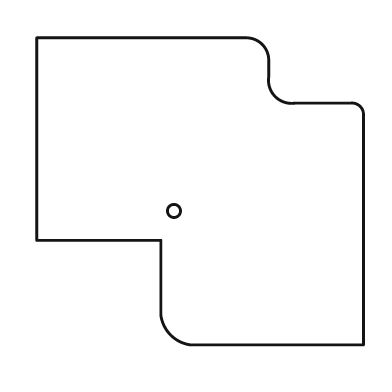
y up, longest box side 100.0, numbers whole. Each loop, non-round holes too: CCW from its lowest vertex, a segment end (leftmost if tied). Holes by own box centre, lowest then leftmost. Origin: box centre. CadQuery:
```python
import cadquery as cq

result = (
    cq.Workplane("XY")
    .moveTo(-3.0, -47.0)
    .lineTo(50.0, -47.0)
    .lineTo(50.0, 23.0)
    .threePointArc((49.0, 26.0), (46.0, 27.0))
    .lineTo(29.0, 27.0)
    .threePointArc((23.0, 29.0), (21.0, 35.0))
    .lineTo(21.0, 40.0)
    .threePointArc((19.0, 45.0), (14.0, 47.0))
    .lineTo(-50.0, 47.0)
    .lineTo(-50.0, -15.0)
    .lineTo(-12.0, -15.0)
    .lineTo(-12.0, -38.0)
    .threePointArc((-9.0, -44.0), (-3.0, -47.0))
    .close()
    .moveTo(-8.0, -6.0)
    .circle(2.0)
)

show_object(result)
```